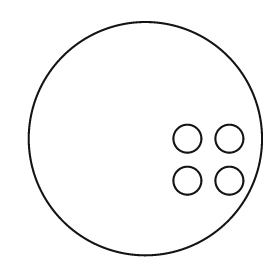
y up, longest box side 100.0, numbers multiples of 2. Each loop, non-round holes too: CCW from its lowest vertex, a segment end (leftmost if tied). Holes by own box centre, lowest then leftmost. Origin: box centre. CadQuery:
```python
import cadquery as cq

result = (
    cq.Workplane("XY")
    .moveTo(0.0, 0.0)
    .circle(50.0)
    .moveTo(18.0, -18.0)
    .circle(6.0)
    .moveTo(36.0, -18.0)
    .circle(6.0)
    .moveTo(18.0, 0.0)
    .circle(6.0)
    .moveTo(36.0, 0.0)
    .circle(6.0)
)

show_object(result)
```